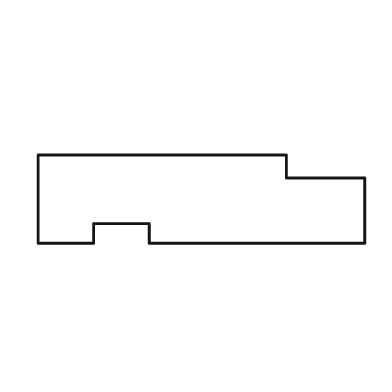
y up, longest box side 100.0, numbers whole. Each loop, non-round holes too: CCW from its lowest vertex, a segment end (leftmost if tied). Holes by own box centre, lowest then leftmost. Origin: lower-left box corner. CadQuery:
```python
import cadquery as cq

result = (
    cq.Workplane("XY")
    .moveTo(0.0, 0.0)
    .lineTo(17.0, 0.0)
    .lineTo(17.0, 6.0)
    .lineTo(34.0, 6.0)
    .lineTo(34.0, 0.0)
    .lineTo(100.0, 0.0)
    .lineTo(100.0, 20.0)
    .lineTo(76.0, 20.0)
    .lineTo(76.0, 27.0)
    .lineTo(0.0, 27.0)
    .close()
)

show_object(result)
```